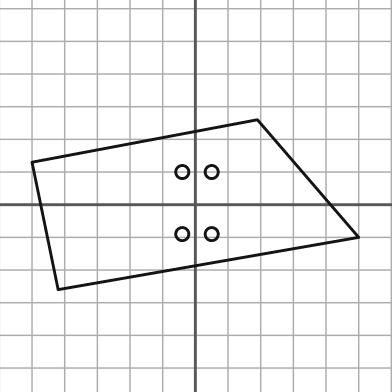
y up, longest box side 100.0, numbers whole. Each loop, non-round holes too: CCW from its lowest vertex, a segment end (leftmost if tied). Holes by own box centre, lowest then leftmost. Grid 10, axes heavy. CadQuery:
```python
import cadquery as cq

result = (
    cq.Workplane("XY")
    .moveTo(-42.0, -26.0)
    .lineTo(50.0, -10.0)
    .lineTo(19.0, 26.0)
    .lineTo(-50.0, 13.0)
    .close()
    .moveTo(-4.0, -9.0)
    .circle(2.0)
    .moveTo(5.0, -9.0)
    .circle(2.0)
    .moveTo(-4.0, 10.0)
    .circle(2.0)
    .moveTo(5.0, 10.0)
    .circle(2.0)
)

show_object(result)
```